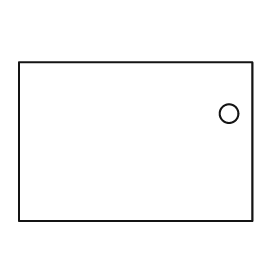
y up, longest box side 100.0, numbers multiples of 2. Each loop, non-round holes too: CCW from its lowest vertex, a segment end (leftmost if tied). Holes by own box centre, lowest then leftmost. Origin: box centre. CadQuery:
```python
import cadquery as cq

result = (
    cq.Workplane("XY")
    .moveTo(-50.0, -34.0)
    .lineTo(50.0, -34.0)
    .lineTo(50.0, 34.0)
    .lineTo(-50.0, 34.0)
    .close()
    .moveTo(40.0, 12.0)
    .circle(4.0)
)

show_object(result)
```